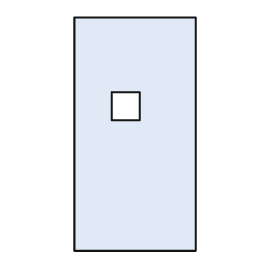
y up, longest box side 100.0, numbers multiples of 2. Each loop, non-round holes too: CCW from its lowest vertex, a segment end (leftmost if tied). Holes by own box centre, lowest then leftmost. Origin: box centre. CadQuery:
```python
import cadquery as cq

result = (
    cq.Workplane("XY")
    .moveTo(-26.0, -50.0)
    .lineTo(26.0, -50.0)
    .lineTo(26.0, 50.0)
    .lineTo(-26.0, 50.0)
    .close()
    .moveTo(-10.0, 6.0)
    .lineTo(2.0, 6.0)
    .lineTo(2.0, 18.0)
    .lineTo(-10.0, 18.0)
    .close()
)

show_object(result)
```